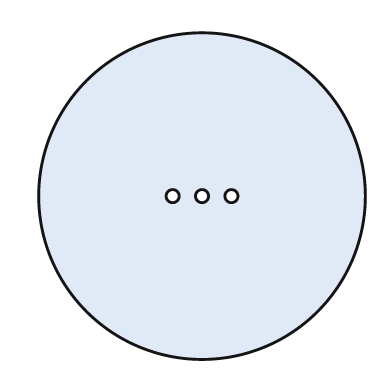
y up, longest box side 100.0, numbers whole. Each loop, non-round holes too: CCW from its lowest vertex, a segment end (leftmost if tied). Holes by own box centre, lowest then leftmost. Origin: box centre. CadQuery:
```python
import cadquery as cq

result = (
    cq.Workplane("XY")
    .moveTo(0.0, 0.0)
    .circle(50.0)
    .moveTo(-9.0, 0.0)
    .circle(2.0)
    .moveTo(0.0, 0.0)
    .circle(2.0)
    .moveTo(9.0, 0.0)
    .circle(2.0)
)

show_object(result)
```